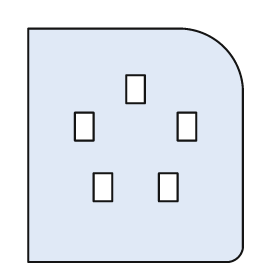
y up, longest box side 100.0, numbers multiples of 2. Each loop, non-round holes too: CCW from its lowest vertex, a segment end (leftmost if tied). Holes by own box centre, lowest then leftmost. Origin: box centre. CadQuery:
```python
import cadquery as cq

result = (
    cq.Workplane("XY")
    .moveTo(-46.0, -50.0)
    .lineTo(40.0, -50.0)
    .threePointArc((44.0, -48.0), (46.0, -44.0))
    .lineTo(46.0, 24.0)
    .threePointArc((38.0, 42.0), (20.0, 50.0))
    .lineTo(-46.0, 50.0)
    .close()
    .moveTo(-18.0, -24.0)
    .lineTo(-10.0, -24.0)
    .lineTo(-10.0, -12.0)
    .lineTo(-18.0, -12.0)
    .close()
    .moveTo(10.0, -24.0)
    .lineTo(18.0, -24.0)
    .lineTo(18.0, -12.0)
    .lineTo(10.0, -12.0)
    .close()
    .moveTo(-26.0, 2.0)
    .lineTo(-18.0, 2.0)
    .lineTo(-18.0, 14.0)
    .lineTo(-26.0, 14.0)
    .close()
    .moveTo(18.0, 2.0)
    .lineTo(26.0, 2.0)
    .lineTo(26.0, 14.0)
    .lineTo(18.0, 14.0)
    .close()
    .moveTo(-4.0, 18.0)
    .lineTo(4.0, 18.0)
    .lineTo(4.0, 30.0)
    .lineTo(-4.0, 30.0)
    .close()
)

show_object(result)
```